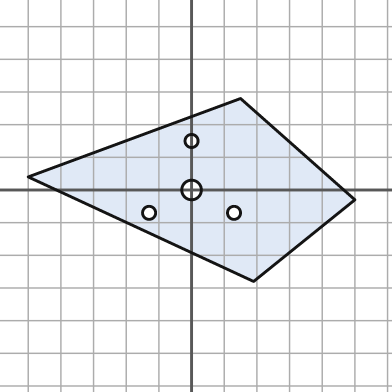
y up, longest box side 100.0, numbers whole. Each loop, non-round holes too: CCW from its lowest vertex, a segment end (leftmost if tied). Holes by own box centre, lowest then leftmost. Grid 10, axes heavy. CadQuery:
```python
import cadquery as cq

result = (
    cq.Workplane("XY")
    .moveTo(19.0, -28.0)
    .lineTo(50.0, -3.0)
    .lineTo(15.0, 28.0)
    .lineTo(-50.0, 4.0)
    .close()
    .moveTo(-13.0, -7.0)
    .circle(2.0)
    .moveTo(13.0, -7.0)
    .circle(2.0)
    .moveTo(0.0, 0.0)
    .circle(3.0)
    .moveTo(0.0, 15.0)
    .circle(2.0)
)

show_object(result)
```